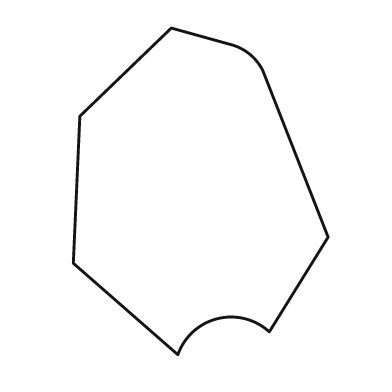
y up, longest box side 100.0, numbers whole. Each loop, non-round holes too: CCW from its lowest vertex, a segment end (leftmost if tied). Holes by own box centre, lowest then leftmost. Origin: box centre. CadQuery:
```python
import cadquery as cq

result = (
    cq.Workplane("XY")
    .moveTo(-7.0, -50.0)
    .threePointArc((5.0, -39.0), (21.0, -43.0))
    .lineTo(39.0, -14.0)
    .lineTo(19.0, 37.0)
    .threePointArc((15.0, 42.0), (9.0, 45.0))
    .lineTo(-9.0, 50.0)
    .lineTo(-37.0, 23.0)
    .lineTo(-39.0, -22.0)
    .close()
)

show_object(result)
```